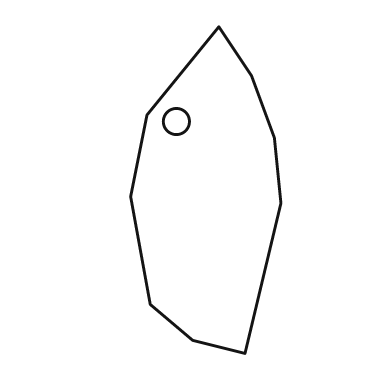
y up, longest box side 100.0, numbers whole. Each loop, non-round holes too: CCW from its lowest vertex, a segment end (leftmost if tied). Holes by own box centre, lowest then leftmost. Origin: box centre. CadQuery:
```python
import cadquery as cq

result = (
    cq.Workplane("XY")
    .moveTo(12.0, -50.0)
    .lineTo(23.0, -4.0)
    .lineTo(21.0, 16.0)
    .lineTo(14.0, 35.0)
    .lineTo(4.0, 50.0)
    .lineTo(-18.0, 23.0)
    .lineTo(-23.0, -2.0)
    .lineTo(-17.0, -35.0)
    .lineTo(-4.0, -46.0)
    .close()
    .moveTo(-9.0, 21.0)
    .circle(4.0)
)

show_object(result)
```